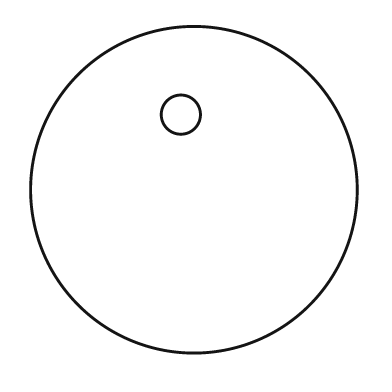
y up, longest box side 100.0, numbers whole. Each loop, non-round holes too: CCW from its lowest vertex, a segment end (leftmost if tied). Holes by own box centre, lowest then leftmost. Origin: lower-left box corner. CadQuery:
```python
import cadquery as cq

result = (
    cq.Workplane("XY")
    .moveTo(50.0, 50.0)
    .circle(50.0)
    .moveTo(46.0, 73.0)
    .circle(6.0)
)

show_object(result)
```